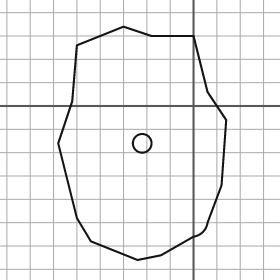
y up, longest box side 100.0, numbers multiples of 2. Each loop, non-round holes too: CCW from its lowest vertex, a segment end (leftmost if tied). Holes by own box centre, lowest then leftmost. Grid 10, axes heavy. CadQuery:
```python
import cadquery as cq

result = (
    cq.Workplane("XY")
    .moveTo(-24.0, -66.0)
    .lineTo(-14.0, -64.0)
    .lineTo(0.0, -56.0)
    .threePointArc((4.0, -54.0), (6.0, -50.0))
    .lineTo(12.0, -34.0)
    .lineTo(14.0, -6.0)
    .lineTo(6.0, 6.0)
    .lineTo(0.0, 30.0)
    .lineTo(-18.0, 30.0)
    .lineTo(-30.0, 34.0)
    .lineTo(-50.0, 26.0)
    .lineTo(-52.0, 2.0)
    .lineTo(-58.0, -16.0)
    .lineTo(-50.0, -48.0)
    .lineTo(-44.0, -58.0)
    .close()
    .moveTo(-22.0, -16.0)
    .circle(4.0)
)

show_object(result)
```